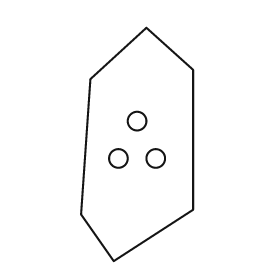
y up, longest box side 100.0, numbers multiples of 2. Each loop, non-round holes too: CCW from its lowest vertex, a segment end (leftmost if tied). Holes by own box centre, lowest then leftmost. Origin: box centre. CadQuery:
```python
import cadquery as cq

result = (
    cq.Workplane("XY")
    .moveTo(-10.0, -50.0)
    .lineTo(24.0, -28.0)
    .lineTo(24.0, 32.0)
    .lineTo(4.0, 50.0)
    .lineTo(-20.0, 28.0)
    .lineTo(-24.0, -30.0)
    .close()
    .moveTo(-8.0, -6.0)
    .circle(4.0)
    .moveTo(8.0, -6.0)
    .circle(4.0)
    .moveTo(0.0, 10.0)
    .circle(4.0)
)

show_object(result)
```